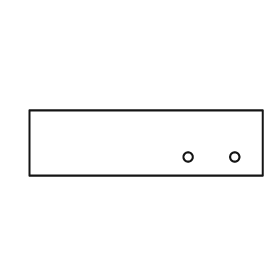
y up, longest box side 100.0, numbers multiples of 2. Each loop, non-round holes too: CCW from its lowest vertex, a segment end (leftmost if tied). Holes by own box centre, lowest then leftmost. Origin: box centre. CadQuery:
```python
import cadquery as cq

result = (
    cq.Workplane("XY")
    .moveTo(-50.0, -14.0)
    .lineTo(50.0, -14.0)
    .lineTo(50.0, 14.0)
    .lineTo(-50.0, 14.0)
    .close()
    .moveTo(18.0, -6.0)
    .circle(2.0)
    .moveTo(38.0, -6.0)
    .circle(2.0)
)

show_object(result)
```